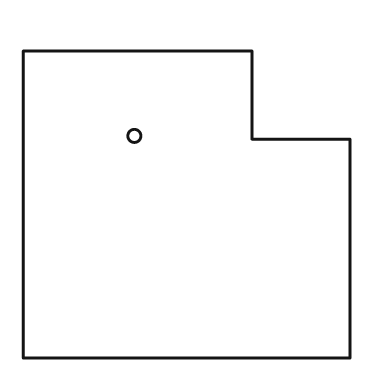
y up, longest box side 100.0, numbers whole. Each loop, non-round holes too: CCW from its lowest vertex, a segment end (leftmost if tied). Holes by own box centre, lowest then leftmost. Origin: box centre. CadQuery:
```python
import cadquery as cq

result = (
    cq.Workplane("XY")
    .moveTo(-50.0, -47.0)
    .lineTo(50.0, -47.0)
    .lineTo(50.0, 20.0)
    .lineTo(20.0, 20.0)
    .lineTo(20.0, 47.0)
    .lineTo(-50.0, 47.0)
    .close()
    .moveTo(-16.0, 21.0)
    .circle(2.0)
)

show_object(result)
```